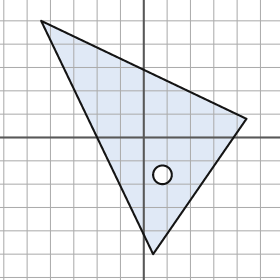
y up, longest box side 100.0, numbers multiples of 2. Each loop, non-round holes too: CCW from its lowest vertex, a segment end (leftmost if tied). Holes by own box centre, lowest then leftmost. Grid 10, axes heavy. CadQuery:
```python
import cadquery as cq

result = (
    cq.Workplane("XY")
    .moveTo(4.0, -50.0)
    .lineTo(44.0, 8.0)
    .lineTo(-44.0, 50.0)
    .close()
    .moveTo(8.0, -16.0)
    .circle(4.0)
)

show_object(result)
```